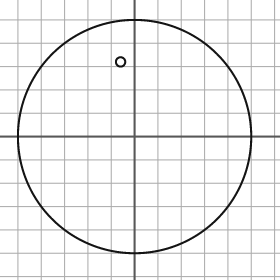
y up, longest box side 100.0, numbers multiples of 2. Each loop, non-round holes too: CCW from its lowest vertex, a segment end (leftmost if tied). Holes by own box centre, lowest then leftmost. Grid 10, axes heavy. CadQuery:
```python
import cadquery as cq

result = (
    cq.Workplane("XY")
    .moveTo(0.0, 0.0)
    .circle(50.0)
    .moveTo(-6.0, 32.0)
    .circle(2.0)
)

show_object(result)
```